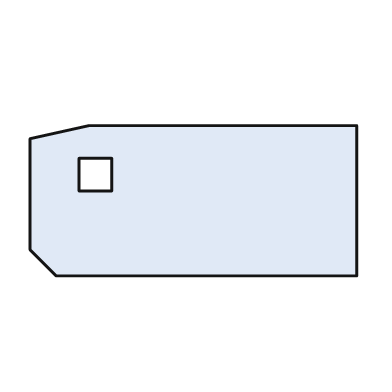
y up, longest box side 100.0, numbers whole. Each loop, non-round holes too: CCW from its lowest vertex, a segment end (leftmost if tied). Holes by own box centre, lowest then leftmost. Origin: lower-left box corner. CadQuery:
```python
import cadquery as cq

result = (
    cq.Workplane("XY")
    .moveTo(8.0, 0.0)
    .lineTo(100.0, 0.0)
    .lineTo(100.0, 46.0)
    .lineTo(18.0, 46.0)
    .lineTo(0.0, 42.0)
    .lineTo(0.0, 8.0)
    .close()
    .moveTo(15.0, 26.0)
    .lineTo(25.0, 26.0)
    .lineTo(25.0, 36.0)
    .lineTo(15.0, 36.0)
    .close()
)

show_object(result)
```